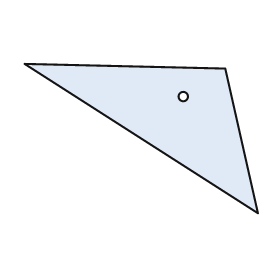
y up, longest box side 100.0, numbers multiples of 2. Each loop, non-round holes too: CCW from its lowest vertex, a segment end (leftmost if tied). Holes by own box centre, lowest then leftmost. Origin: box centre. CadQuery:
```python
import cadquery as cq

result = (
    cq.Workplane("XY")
    .moveTo(50.0, -32.0)
    .lineTo(36.0, 30.0)
    .lineTo(-50.0, 32.0)
    .close()
    .moveTo(18.0, 18.0)
    .circle(2.0)
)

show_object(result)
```